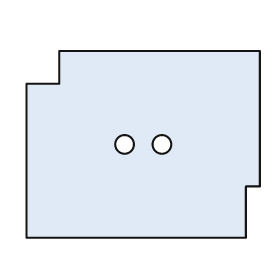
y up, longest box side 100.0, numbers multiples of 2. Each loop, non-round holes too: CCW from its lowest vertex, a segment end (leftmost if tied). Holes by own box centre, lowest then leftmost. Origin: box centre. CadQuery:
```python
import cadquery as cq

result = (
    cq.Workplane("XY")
    .moveTo(-50.0, -40.0)
    .lineTo(44.0, -40.0)
    .lineTo(44.0, -18.0)
    .lineTo(50.0, -18.0)
    .lineTo(50.0, 40.0)
    .lineTo(-36.0, 40.0)
    .lineTo(-36.0, 26.0)
    .lineTo(-50.0, 26.0)
    .close()
    .moveTo(-8.0, 0.0)
    .circle(4.0)
    .moveTo(8.0, 0.0)
    .circle(4.0)
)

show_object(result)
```